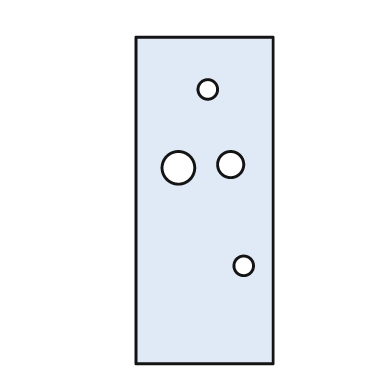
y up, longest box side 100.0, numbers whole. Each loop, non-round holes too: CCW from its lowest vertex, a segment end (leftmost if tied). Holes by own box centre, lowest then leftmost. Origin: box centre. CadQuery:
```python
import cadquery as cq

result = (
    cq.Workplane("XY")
    .moveTo(-21.0, -50.0)
    .lineTo(21.0, -50.0)
    .lineTo(21.0, 50.0)
    .lineTo(-21.0, 50.0)
    .close()
    .moveTo(12.0, -20.0)
    .circle(3.0)
    .moveTo(-8.0, 10.0)
    .circle(5.0)
    .moveTo(8.0, 11.0)
    .circle(4.0)
    .moveTo(1.0, 34.0)
    .circle(3.0)
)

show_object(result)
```